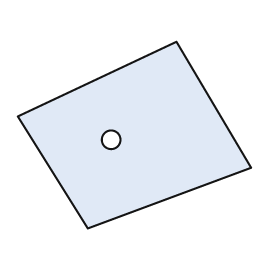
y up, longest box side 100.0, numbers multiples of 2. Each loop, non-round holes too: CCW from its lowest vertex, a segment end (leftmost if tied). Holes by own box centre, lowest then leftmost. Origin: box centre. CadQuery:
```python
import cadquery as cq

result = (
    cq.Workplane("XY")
    .moveTo(-20.0, -40.0)
    .lineTo(50.0, -14.0)
    .lineTo(18.0, 40.0)
    .lineTo(-50.0, 8.0)
    .close()
    .moveTo(-10.0, -2.0)
    .circle(4.0)
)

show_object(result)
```